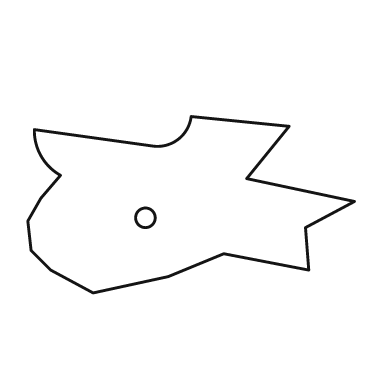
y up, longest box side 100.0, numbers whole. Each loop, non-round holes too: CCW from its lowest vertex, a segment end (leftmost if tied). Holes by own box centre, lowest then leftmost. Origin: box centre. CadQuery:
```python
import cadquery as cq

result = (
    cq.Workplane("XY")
    .moveTo(-30.0, -27.0)
    .lineTo(-7.0, -22.0)
    .lineTo(10.0, -15.0)
    .lineTo(36.0, -20.0)
    .lineTo(35.0, -7.0)
    .lineTo(50.0, 1.0)
    .lineTo(17.0, 8.0)
    .lineTo(30.0, 24.0)
    .lineTo(0.0, 27.0)
    .threePointArc((-4.0, 20.0), (-12.0, 18.0))
    .lineTo(-48.0, 23.0)
    .threePointArc((-46.0, 15.0), (-40.0, 9.0))
    .lineTo(-46.0, 2.0)
    .lineTo(-50.0, -5.0)
    .lineTo(-49.0, -14.0)
    .lineTo(-43.0, -20.0)
    .close()
    .moveTo(-14.0, -4.0)
    .circle(3.0)
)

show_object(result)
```